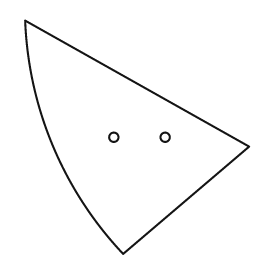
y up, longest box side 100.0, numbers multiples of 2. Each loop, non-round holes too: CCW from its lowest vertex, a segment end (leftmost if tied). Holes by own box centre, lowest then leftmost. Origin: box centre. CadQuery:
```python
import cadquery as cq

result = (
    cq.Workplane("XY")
    .moveTo(-6.0, -50.0)
    .lineTo(48.0, -4.0)
    .lineTo(-48.0, 50.0)
    .threePointArc((-36.0, -4.0), (-6.0, -50.0))
    .close()
    .moveTo(-10.0, 0.0)
    .circle(2.0)
    .moveTo(12.0, 0.0)
    .circle(2.0)
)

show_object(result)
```